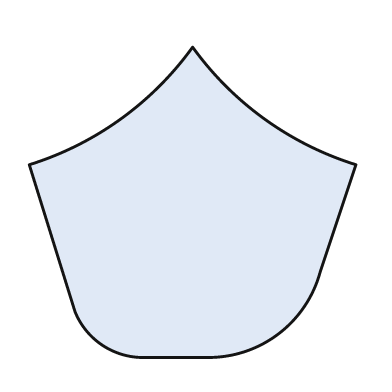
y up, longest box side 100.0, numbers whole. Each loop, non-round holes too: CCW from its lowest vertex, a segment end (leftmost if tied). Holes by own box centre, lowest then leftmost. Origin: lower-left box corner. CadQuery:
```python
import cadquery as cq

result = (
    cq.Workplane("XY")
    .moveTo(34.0, 0.0)
    .lineTo(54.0, 0.0)
    .threePointArc((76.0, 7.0), (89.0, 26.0))
    .lineTo(100.0, 59.0)
    .threePointArc((72.0, 73.0), (50.0, 95.0))
    .threePointArc((28.0, 73.0), (0.0, 59.0))
    .lineTo(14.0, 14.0)
    .threePointArc((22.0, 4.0), (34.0, 0.0))
    .close()
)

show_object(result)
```